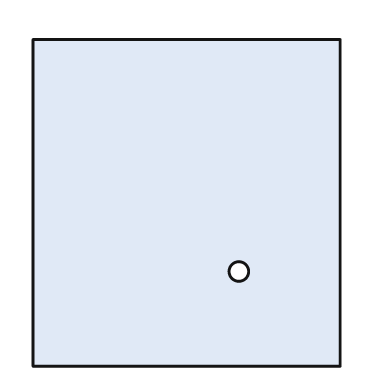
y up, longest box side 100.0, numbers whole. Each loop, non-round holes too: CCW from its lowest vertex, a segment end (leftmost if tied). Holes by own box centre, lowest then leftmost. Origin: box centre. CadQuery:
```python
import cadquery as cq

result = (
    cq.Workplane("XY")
    .moveTo(-47.0, -50.0)
    .lineTo(47.0, -50.0)
    .lineTo(47.0, 50.0)
    .lineTo(-47.0, 50.0)
    .close()
    .moveTo(16.0, -21.0)
    .circle(3.0)
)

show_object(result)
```